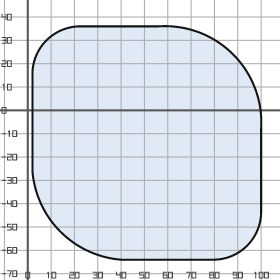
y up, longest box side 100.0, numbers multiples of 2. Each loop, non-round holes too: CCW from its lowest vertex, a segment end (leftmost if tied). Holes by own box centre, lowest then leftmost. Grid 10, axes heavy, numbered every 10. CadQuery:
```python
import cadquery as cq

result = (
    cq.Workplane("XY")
    .moveTo(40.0, -64.0)
    .lineTo(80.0, -64.0)
    .threePointArc((94.0, -58.0), (100.0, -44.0))
    .lineTo(100.0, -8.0)
    .threePointArc((88.0, 24.0), (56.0, 36.0))
    .lineTo(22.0, 36.0)
    .threePointArc((8.0, 30.0), (2.0, 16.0))
    .lineTo(2.0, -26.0)
    .threePointArc((14.0, -52.0), (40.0, -64.0))
    .close()
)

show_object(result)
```